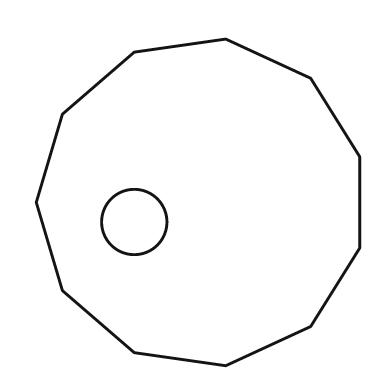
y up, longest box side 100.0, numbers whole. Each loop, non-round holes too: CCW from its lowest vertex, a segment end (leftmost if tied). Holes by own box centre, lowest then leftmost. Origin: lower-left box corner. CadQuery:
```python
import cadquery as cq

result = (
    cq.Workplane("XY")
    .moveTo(58.0, 0.0)
    .lineTo(84.0, 12.0)
    .lineTo(99.0, 36.0)
    .lineTo(99.0, 64.0)
    .lineTo(84.0, 88.0)
    .lineTo(58.0, 100.0)
    .lineTo(30.0, 96.0)
    .lineTo(8.0, 77.0)
    .lineTo(0.0, 50.0)
    .lineTo(8.0, 23.0)
    .lineTo(30.0, 4.0)
    .close()
    .moveTo(30.0, 44.0)
    .circle(10.0)
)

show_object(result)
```